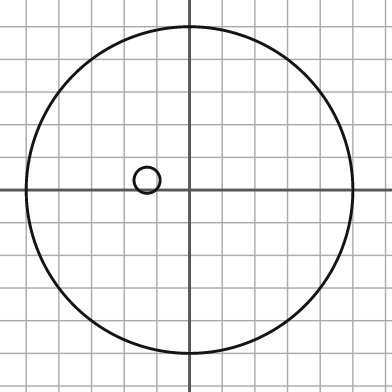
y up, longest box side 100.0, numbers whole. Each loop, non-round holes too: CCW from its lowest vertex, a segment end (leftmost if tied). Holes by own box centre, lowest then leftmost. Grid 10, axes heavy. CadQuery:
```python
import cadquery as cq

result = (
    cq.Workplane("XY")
    .moveTo(0.0, 0.0)
    .circle(50.0)
    .moveTo(-13.0, 3.0)
    .circle(4.0)
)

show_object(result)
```